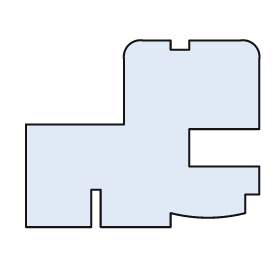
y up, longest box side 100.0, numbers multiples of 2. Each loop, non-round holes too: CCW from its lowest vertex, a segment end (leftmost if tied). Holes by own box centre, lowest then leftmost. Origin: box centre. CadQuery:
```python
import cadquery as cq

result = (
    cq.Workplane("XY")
    .moveTo(-50.0, -40.0)
    .lineTo(-22.0, -40.0)
    .lineTo(-22.0, -24.0)
    .lineTo(-18.0, -24.0)
    .lineTo(-18.0, -40.0)
    .lineTo(12.0, -40.0)
    .lineTo(12.0, -34.0)
    .threePointArc((28.0, -36.0), (44.0, -34.0))
    .lineTo(44.0, -26.0)
    .lineTo(50.0, -26.0)
    .lineTo(50.0, -14.0)
    .lineTo(20.0, -14.0)
    .lineTo(20.0, 2.0)
    .lineTo(50.0, 2.0)
    .lineTo(50.0, 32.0)
    .threePointArc((48.0, 38.0), (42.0, 40.0))
    .lineTo(20.0, 40.0)
    .lineTo(20.0, 36.0)
    .lineTo(12.0, 36.0)
    .lineTo(12.0, 40.0)
    .lineTo(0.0, 40.0)
    .threePointArc((-6.0, 38.0), (-8.0, 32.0))
    .lineTo(-8.0, 4.0)
    .lineTo(-50.0, 4.0)
    .close()
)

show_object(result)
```